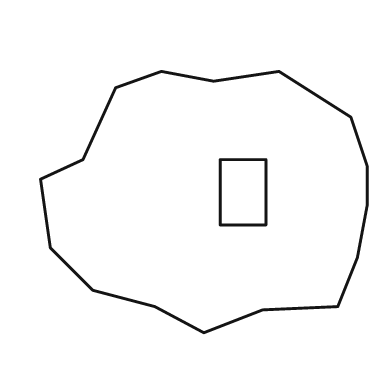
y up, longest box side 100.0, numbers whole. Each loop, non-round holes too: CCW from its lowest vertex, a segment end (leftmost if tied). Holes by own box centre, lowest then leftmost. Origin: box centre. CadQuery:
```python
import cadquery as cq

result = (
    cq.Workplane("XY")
    .moveTo(0.0, -40.0)
    .lineTo(18.0, -33.0)
    .lineTo(41.0, -32.0)
    .lineTo(47.0, -17.0)
    .lineTo(50.0, -1.0)
    .lineTo(50.0, 11.0)
    .lineTo(45.0, 26.0)
    .lineTo(23.0, 40.0)
    .lineTo(3.0, 37.0)
    .lineTo(-13.0, 40.0)
    .lineTo(-27.0, 35.0)
    .lineTo(-37.0, 13.0)
    .lineTo(-50.0, 7.0)
    .lineTo(-47.0, -14.0)
    .lineTo(-34.0, -27.0)
    .lineTo(-15.0, -32.0)
    .close()
    .moveTo(5.0, -7.0)
    .lineTo(19.0, -7.0)
    .lineTo(19.0, 13.0)
    .lineTo(5.0, 13.0)
    .close()
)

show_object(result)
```